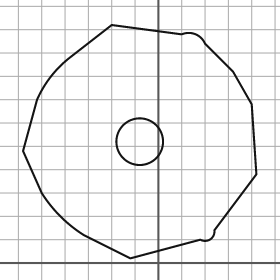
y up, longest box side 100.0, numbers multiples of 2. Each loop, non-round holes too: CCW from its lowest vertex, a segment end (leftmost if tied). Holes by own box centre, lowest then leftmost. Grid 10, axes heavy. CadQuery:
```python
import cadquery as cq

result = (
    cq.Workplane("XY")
    .moveTo(-12.0, 2.0)
    .lineTo(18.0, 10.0)
    .threePointArc((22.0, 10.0), (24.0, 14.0))
    .lineTo(42.0, 38.0)
    .lineTo(40.0, 68.0)
    .lineTo(32.0, 82.0)
    .lineTo(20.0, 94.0)
    .threePointArc((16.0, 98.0), (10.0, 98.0))
    .lineTo(-20.0, 102.0)
    .lineTo(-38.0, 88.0)
    .threePointArc((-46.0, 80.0), (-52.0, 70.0))
    .lineTo(-58.0, 48.0)
    .lineTo(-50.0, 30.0)
    .threePointArc((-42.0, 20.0), (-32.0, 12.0))
    .close()
    .moveTo(-8.0, 52.0)
    .circle(10.0)
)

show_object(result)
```